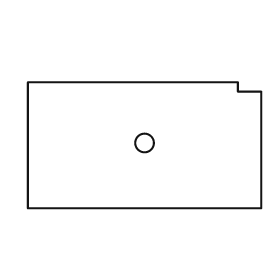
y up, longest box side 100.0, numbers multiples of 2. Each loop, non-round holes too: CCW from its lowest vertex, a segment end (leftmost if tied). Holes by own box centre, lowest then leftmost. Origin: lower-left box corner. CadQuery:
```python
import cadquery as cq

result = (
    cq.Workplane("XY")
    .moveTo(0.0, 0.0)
    .lineTo(100.0, 0.0)
    .lineTo(100.0, 50.0)
    .lineTo(90.0, 50.0)
    .lineTo(90.0, 54.0)
    .lineTo(0.0, 54.0)
    .close()
    .moveTo(50.0, 28.0)
    .circle(4.0)
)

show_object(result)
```